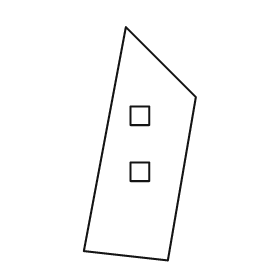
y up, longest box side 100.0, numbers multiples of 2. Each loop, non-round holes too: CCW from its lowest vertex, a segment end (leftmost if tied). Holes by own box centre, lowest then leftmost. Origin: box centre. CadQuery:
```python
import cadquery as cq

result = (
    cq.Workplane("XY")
    .moveTo(12.0, -50.0)
    .lineTo(24.0, 20.0)
    .lineTo(-6.0, 50.0)
    .lineTo(-24.0, -46.0)
    .close()
    .moveTo(-4.0, -16.0)
    .lineTo(4.0, -16.0)
    .lineTo(4.0, -8.0)
    .lineTo(-4.0, -8.0)
    .close()
    .moveTo(-4.0, 8.0)
    .lineTo(4.0, 8.0)
    .lineTo(4.0, 16.0)
    .lineTo(-4.0, 16.0)
    .close()
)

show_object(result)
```